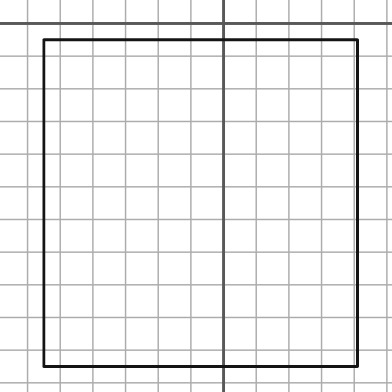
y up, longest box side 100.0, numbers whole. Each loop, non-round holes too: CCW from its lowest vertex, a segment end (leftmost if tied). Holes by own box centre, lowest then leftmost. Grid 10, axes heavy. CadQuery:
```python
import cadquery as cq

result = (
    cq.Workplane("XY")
    .moveTo(-55.0, -105.0)
    .lineTo(41.0, -105.0)
    .lineTo(41.0, -5.0)
    .lineTo(-55.0, -5.0)
    .close()
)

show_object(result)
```